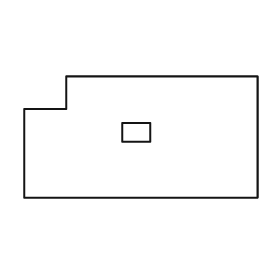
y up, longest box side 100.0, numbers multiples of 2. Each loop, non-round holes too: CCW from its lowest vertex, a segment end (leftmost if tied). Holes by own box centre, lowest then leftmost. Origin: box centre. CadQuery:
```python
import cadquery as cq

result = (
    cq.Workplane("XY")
    .moveTo(-50.0, -26.0)
    .lineTo(50.0, -26.0)
    .lineTo(50.0, 26.0)
    .lineTo(-32.0, 26.0)
    .lineTo(-32.0, 12.0)
    .lineTo(-50.0, 12.0)
    .close()
    .moveTo(-8.0, -2.0)
    .lineTo(4.0, -2.0)
    .lineTo(4.0, 6.0)
    .lineTo(-8.0, 6.0)
    .close()
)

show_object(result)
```